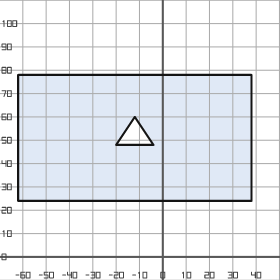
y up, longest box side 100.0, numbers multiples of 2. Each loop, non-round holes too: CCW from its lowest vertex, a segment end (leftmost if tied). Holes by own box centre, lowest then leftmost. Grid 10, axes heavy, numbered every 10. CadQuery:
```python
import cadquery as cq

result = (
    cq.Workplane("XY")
    .moveTo(-62.0, 24.0)
    .lineTo(38.0, 24.0)
    .lineTo(38.0, 78.0)
    .lineTo(-62.0, 78.0)
    .close()
    .moveTo(-20.0, 48.0)
    .lineTo(-4.0, 48.0)
    .lineTo(-12.0, 60.0)
    .close()
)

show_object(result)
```